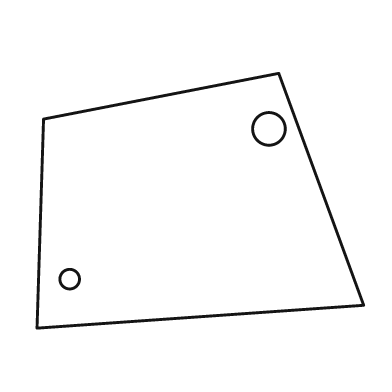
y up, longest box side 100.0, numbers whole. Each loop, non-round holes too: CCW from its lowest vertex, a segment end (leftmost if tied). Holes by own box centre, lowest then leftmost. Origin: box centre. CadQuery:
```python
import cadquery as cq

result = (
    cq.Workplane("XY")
    .moveTo(-50.0, -39.0)
    .lineTo(50.0, -32.0)
    .lineTo(24.0, 39.0)
    .lineTo(-48.0, 25.0)
    .close()
    .moveTo(-40.0, -24.0)
    .circle(3.0)
    .moveTo(21.0, 22.0)
    .circle(5.0)
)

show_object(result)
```